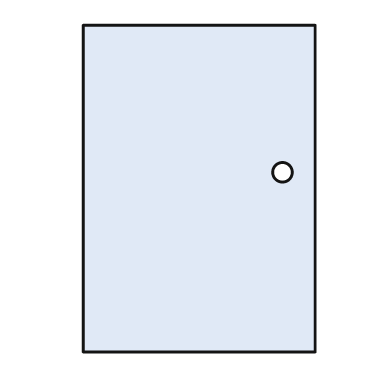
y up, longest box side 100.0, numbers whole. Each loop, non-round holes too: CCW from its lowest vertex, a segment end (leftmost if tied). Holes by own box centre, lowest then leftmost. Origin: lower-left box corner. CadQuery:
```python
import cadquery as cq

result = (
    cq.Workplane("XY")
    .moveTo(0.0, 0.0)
    .lineTo(71.0, 0.0)
    .lineTo(71.0, 100.0)
    .lineTo(0.0, 100.0)
    .close()
    .moveTo(61.0, 55.0)
    .circle(3.0)
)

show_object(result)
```